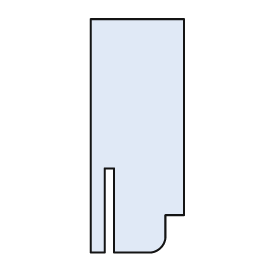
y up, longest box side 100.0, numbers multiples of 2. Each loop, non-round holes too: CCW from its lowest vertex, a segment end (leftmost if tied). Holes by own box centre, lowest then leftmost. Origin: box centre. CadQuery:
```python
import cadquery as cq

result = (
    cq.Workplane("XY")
    .moveTo(-20.0, -50.0)
    .lineTo(-14.0, -50.0)
    .lineTo(-14.0, -14.0)
    .lineTo(-10.0, -14.0)
    .lineTo(-10.0, -50.0)
    .lineTo(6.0, -50.0)
    .threePointArc((10.0, -48.0), (12.0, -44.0))
    .lineTo(12.0, -34.0)
    .lineTo(20.0, -34.0)
    .lineTo(20.0, 50.0)
    .lineTo(-20.0, 50.0)
    .close()
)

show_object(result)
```